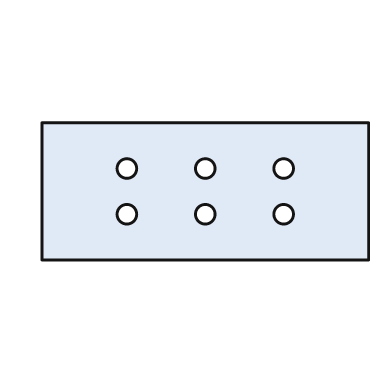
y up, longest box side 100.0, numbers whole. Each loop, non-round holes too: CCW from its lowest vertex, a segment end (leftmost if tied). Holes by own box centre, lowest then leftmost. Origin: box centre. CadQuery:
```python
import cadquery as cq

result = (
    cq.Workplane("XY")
    .moveTo(-50.0, -21.0)
    .lineTo(50.0, -21.0)
    .lineTo(50.0, 21.0)
    .lineTo(-50.0, 21.0)
    .close()
    .moveTo(-24.0, -7.0)
    .circle(3.0)
    .moveTo(0.0, -7.0)
    .circle(3.0)
    .moveTo(24.0, -7.0)
    .circle(3.0)
    .moveTo(-24.0, 7.0)
    .circle(3.0)
    .moveTo(0.0, 7.0)
    .circle(3.0)
    .moveTo(24.0, 7.0)
    .circle(3.0)
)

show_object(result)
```